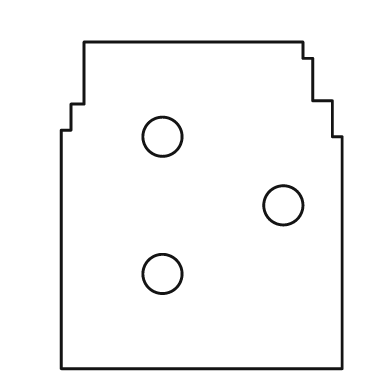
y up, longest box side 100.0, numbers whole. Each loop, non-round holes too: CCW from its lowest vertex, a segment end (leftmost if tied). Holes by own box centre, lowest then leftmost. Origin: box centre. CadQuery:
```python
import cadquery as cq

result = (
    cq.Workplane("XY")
    .moveTo(-43.0, -50.0)
    .lineTo(43.0, -50.0)
    .lineTo(43.0, 21.0)
    .lineTo(40.0, 21.0)
    .lineTo(40.0, 32.0)
    .lineTo(34.0, 32.0)
    .lineTo(34.0, 45.0)
    .lineTo(31.0, 45.0)
    .lineTo(31.0, 50.0)
    .lineTo(-36.0, 50.0)
    .lineTo(-36.0, 31.0)
    .lineTo(-40.0, 31.0)
    .lineTo(-40.0, 23.0)
    .lineTo(-43.0, 23.0)
    .close()
    .moveTo(-12.0, -21.0)
    .circle(6.0)
    .moveTo(25.0, 0.0)
    .circle(6.0)
    .moveTo(-12.0, 21.0)
    .circle(6.0)
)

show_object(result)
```